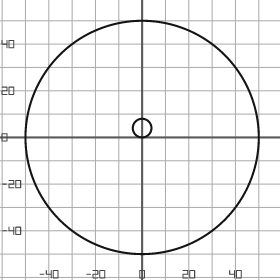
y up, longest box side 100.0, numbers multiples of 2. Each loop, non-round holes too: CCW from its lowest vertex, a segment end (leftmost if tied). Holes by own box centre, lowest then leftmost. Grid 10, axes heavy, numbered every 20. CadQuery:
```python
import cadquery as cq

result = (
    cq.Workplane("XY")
    .moveTo(0.0, 0.0)
    .circle(50.0)
    .moveTo(0.0, 4.0)
    .circle(4.0)
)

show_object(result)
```